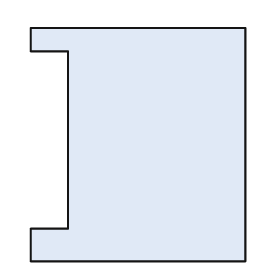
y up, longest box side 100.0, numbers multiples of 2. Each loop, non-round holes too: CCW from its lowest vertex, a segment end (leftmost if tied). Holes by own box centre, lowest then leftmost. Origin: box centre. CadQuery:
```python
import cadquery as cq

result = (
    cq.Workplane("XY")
    .moveTo(-46.0, -50.0)
    .lineTo(46.0, -50.0)
    .lineTo(46.0, 50.0)
    .lineTo(-46.0, 50.0)
    .lineTo(-46.0, 40.0)
    .lineTo(-30.0, 40.0)
    .lineTo(-30.0, -36.0)
    .lineTo(-46.0, -36.0)
    .close()
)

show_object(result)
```